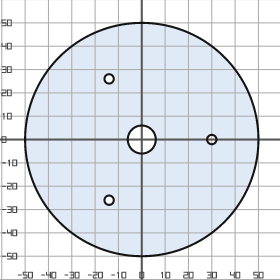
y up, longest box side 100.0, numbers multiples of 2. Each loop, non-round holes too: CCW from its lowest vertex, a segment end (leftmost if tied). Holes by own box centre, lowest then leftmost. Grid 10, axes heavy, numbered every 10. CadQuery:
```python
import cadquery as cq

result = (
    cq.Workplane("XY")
    .moveTo(0.0, 0.0)
    .circle(50.0)
    .moveTo(-14.0, -26.0)
    .circle(2.0)
    .moveTo(0.0, 0.0)
    .circle(6.0)
    .moveTo(30.0, 0.0)
    .circle(2.0)
    .moveTo(-14.0, 26.0)
    .circle(2.0)
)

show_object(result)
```